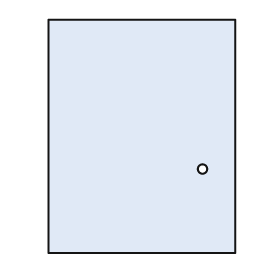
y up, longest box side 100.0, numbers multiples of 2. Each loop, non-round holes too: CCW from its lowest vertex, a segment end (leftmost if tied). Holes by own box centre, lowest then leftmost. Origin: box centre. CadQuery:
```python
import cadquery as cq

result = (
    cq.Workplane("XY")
    .moveTo(-40.0, -50.0)
    .lineTo(40.0, -50.0)
    .lineTo(40.0, 50.0)
    .lineTo(-40.0, 50.0)
    .close()
    .moveTo(26.0, -14.0)
    .circle(2.0)
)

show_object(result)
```